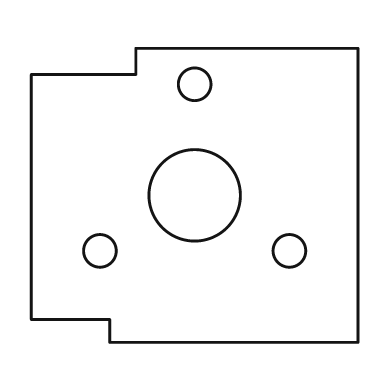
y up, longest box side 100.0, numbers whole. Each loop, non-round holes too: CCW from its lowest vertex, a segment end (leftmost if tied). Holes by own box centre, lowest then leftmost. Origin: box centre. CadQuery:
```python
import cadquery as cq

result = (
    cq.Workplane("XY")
    .moveTo(-26.0, -45.0)
    .lineTo(50.0, -45.0)
    .lineTo(50.0, 45.0)
    .lineTo(-18.0, 45.0)
    .lineTo(-18.0, 37.0)
    .lineTo(-50.0, 37.0)
    .lineTo(-50.0, -38.0)
    .lineTo(-26.0, -38.0)
    .close()
    .moveTo(-29.0, -17.0)
    .circle(5.0)
    .moveTo(29.0, -17.0)
    .circle(5.0)
    .moveTo(0.0, 0.0)
    .circle(14.0)
    .moveTo(0.0, 34.0)
    .circle(5.0)
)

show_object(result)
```